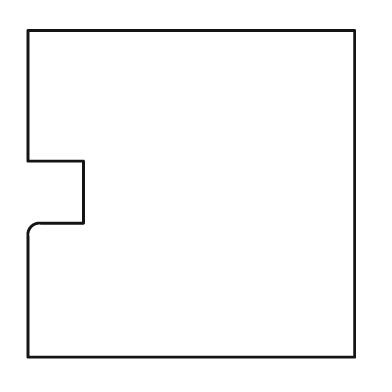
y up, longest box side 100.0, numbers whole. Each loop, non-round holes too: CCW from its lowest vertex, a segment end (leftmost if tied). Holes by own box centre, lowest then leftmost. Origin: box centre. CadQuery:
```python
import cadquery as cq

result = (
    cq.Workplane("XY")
    .moveTo(-50.0, -50.0)
    .lineTo(50.0, -50.0)
    .lineTo(50.0, 50.0)
    .lineTo(-50.0, 50.0)
    .lineTo(-50.0, 10.0)
    .lineTo(-33.0, 10.0)
    .lineTo(-33.0, -9.0)
    .lineTo(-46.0, -9.0)
    .threePointArc((-49.0, -10.0), (-50.0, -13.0))
    .close()
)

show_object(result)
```